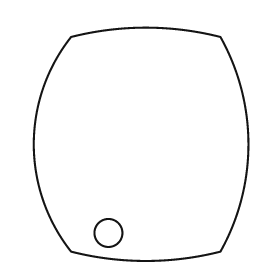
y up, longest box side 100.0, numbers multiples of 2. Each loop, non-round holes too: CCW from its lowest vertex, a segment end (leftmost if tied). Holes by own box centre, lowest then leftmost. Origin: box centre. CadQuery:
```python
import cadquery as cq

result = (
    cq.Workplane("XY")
    .moveTo(-30.0, -46.0)
    .threePointArc((2.0, -50.0), (34.0, -46.0))
    .threePointArc((46.0, 0.0), (34.0, 46.0))
    .threePointArc((2.0, 50.0), (-30.0, 46.0))
    .threePointArc((-46.0, 0.0), (-30.0, -46.0))
    .close()
    .moveTo(-14.0, -38.0)
    .circle(6.0)
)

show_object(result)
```